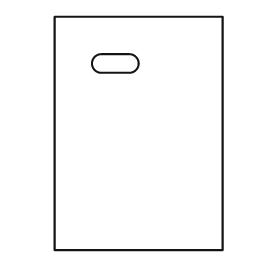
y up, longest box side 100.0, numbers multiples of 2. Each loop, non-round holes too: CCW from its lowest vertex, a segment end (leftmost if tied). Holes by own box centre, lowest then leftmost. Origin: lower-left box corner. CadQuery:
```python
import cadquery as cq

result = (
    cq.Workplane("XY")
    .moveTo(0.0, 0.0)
    .lineTo(72.0, 0.0)
    .lineTo(72.0, 100.0)
    .lineTo(0.0, 100.0)
    .close()
    .moveTo(20.0, 76.0)
    .lineTo(32.0, 76.0)
    .threePointArc((36.0, 80.0), (32.0, 84.0))
    .lineTo(20.0, 84.0)
    .threePointArc((16.0, 80.0), (20.0, 76.0))
    .close()
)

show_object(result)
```